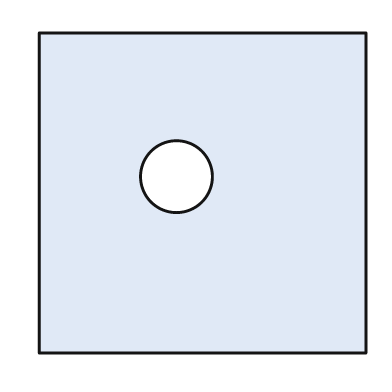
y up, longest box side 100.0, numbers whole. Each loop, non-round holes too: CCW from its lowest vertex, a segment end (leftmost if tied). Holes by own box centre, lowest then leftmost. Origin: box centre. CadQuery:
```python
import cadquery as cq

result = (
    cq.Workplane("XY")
    .moveTo(-50.0, -49.0)
    .lineTo(50.0, -49.0)
    .lineTo(50.0, 49.0)
    .lineTo(-50.0, 49.0)
    .close()
    .moveTo(-8.0, 5.0)
    .circle(11.0)
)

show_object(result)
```